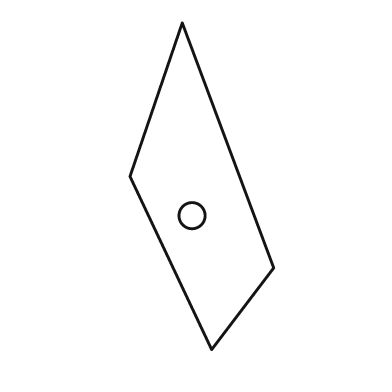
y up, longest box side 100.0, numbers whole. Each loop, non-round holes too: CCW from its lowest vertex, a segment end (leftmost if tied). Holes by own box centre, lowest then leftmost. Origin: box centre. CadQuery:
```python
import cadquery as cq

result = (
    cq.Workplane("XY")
    .moveTo(3.0, -50.0)
    .lineTo(22.0, -25.0)
    .lineTo(-6.0, 50.0)
    .lineTo(-22.0, 3.0)
    .close()
    .moveTo(-3.0, -9.0)
    .circle(4.0)
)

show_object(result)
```